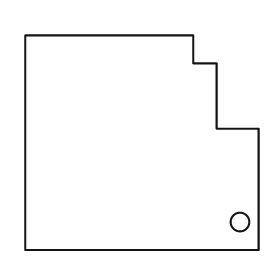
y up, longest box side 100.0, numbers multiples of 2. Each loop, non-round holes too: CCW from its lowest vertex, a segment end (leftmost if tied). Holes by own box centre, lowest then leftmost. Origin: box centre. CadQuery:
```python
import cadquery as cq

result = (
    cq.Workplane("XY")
    .moveTo(-50.0, -46.0)
    .lineTo(50.0, -46.0)
    .lineTo(50.0, 6.0)
    .lineTo(32.0, 6.0)
    .lineTo(32.0, 34.0)
    .lineTo(22.0, 34.0)
    .lineTo(22.0, 46.0)
    .lineTo(-50.0, 46.0)
    .close()
    .moveTo(42.0, -34.0)
    .circle(4.0)
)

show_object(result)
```